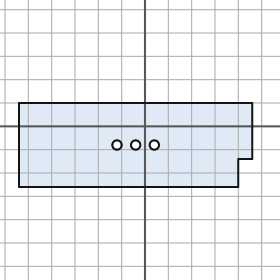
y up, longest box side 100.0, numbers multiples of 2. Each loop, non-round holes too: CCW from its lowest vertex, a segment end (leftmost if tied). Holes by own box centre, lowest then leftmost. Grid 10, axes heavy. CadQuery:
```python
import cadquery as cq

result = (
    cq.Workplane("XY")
    .moveTo(-54.0, -26.0)
    .lineTo(40.0, -26.0)
    .lineTo(40.0, -14.0)
    .lineTo(46.0, -14.0)
    .lineTo(46.0, 10.0)
    .lineTo(-54.0, 10.0)
    .close()
    .moveTo(-12.0, -8.0)
    .circle(2.0)
    .moveTo(-4.0, -8.0)
    .circle(2.0)
    .moveTo(4.0, -8.0)
    .circle(2.0)
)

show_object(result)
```